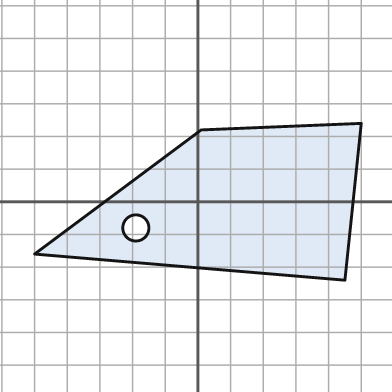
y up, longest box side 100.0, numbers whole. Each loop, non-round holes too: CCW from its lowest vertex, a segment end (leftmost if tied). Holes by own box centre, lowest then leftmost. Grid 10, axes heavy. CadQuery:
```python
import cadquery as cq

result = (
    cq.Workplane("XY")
    .moveTo(45.0, -24.0)
    .lineTo(50.0, 24.0)
    .lineTo(1.0, 22.0)
    .lineTo(-50.0, -16.0)
    .close()
    .moveTo(-19.0, -8.0)
    .circle(4.0)
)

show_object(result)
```